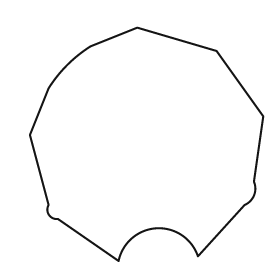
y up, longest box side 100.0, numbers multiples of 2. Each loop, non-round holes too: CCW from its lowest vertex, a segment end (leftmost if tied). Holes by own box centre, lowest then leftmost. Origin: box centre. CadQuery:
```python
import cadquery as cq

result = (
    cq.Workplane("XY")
    .moveTo(-12.0, -50.0)
    .threePointArc((4.0, -36.0), (22.0, -48.0))
    .lineTo(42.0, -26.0)
    .threePointArc((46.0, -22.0), (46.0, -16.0))
    .lineTo(50.0, 12.0)
    .lineTo(30.0, 40.0)
    .lineTo(-4.0, 50.0)
    .lineTo(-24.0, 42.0)
    .threePointArc((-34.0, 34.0), (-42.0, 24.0))
    .lineTo(-50.0, 4.0)
    .lineTo(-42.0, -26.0)
    .threePointArc((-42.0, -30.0), (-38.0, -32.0))
    .close()
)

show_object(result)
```